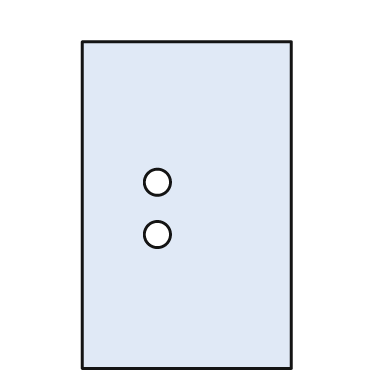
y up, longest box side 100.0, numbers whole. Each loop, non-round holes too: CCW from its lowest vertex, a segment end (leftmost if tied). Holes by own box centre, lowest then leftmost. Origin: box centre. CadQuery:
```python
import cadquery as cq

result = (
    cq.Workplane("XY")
    .moveTo(-32.0, -50.0)
    .lineTo(32.0, -50.0)
    .lineTo(32.0, 50.0)
    .lineTo(-32.0, 50.0)
    .close()
    .moveTo(-9.0, -9.0)
    .circle(4.0)
    .moveTo(-9.0, 7.0)
    .circle(4.0)
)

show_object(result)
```